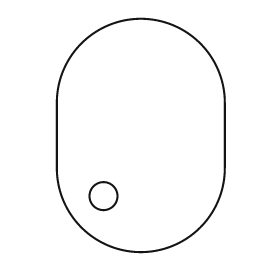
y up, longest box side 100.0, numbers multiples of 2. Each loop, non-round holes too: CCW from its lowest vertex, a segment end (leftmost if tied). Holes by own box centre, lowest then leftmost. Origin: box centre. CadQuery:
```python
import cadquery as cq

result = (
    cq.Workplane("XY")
    .moveTo(-36.0, -14.0)
    .threePointArc((0.0, -50.0), (36.0, -14.0))
    .lineTo(36.0, 14.0)
    .threePointArc((0.0, 50.0), (-36.0, 14.0))
    .close()
    .moveTo(-16.0, -26.0)
    .circle(6.0)
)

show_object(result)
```